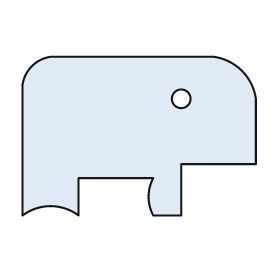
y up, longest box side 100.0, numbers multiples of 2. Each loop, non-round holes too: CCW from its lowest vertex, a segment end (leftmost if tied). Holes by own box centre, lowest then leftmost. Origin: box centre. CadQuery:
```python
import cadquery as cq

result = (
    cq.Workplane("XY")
    .moveTo(-50.0, -34.0)
    .threePointArc((-38.0, -30.0), (-26.0, -34.0))
    .lineTo(-26.0, -18.0)
    .lineTo(6.0, -18.0)
    .threePointArc((4.0, -26.0), (6.0, -34.0))
    .lineTo(18.0, -34.0)
    .lineTo(18.0, -12.0)
    .lineTo(50.0, -12.0)
    .lineTo(50.0, 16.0)
    .threePointArc((44.0, 28.0), (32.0, 34.0))
    .lineTo(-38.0, 34.0)
    .threePointArc((-46.0, 30.0), (-50.0, 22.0))
    .close()
    .moveTo(18.0, 16.0)
    .circle(4.0)
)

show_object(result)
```